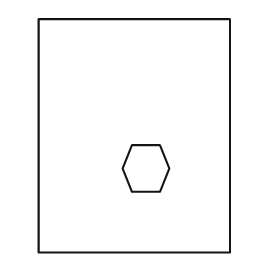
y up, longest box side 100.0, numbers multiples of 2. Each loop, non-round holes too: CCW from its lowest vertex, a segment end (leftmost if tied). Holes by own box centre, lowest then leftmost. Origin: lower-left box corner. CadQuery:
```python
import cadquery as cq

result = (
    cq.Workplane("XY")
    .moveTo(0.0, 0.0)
    .lineTo(82.0, 0.0)
    .lineTo(82.0, 100.0)
    .lineTo(0.0, 100.0)
    .close()
    .moveTo(40.0, 26.0)
    .lineTo(52.0, 26.0)
    .lineTo(56.0, 36.0)
    .lineTo(52.0, 46.0)
    .lineTo(40.0, 46.0)
    .lineTo(36.0, 36.0)
    .close()
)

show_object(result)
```